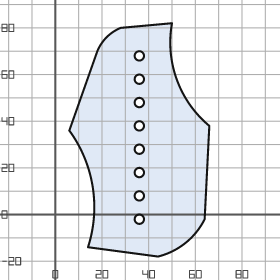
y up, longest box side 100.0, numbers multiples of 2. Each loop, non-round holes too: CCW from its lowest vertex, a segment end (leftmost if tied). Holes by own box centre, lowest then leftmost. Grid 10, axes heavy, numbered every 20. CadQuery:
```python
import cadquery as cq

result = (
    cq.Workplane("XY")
    .moveTo(44.0, -18.0)
    .threePointArc((56.0, -12.0), (64.0, -2.0))
    .lineTo(66.0, 38.0)
    .threePointArc((52.0, 58.0), (50.0, 82.0))
    .lineTo(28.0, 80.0)
    .threePointArc((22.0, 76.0), (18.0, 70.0))
    .lineTo(6.0, 36.0)
    .threePointArc((16.0, 12.0), (14.0, -14.0))
    .close()
    .moveTo(36.0, -2.0)
    .circle(2.0)
    .moveTo(36.0, 8.0)
    .circle(2.0)
    .moveTo(36.0, 18.0)
    .circle(2.0)
    .moveTo(36.0, 28.0)
    .circle(2.0)
    .moveTo(36.0, 38.0)
    .circle(2.0)
    .moveTo(36.0, 48.0)
    .circle(2.0)
    .moveTo(36.0, 58.0)
    .circle(2.0)
    .moveTo(36.0, 68.0)
    .circle(2.0)
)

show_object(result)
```